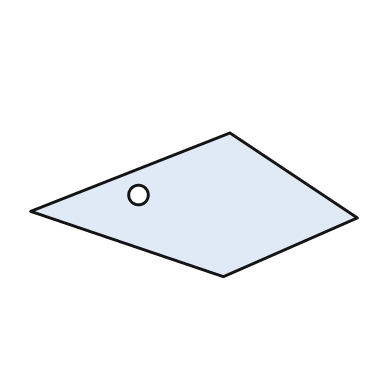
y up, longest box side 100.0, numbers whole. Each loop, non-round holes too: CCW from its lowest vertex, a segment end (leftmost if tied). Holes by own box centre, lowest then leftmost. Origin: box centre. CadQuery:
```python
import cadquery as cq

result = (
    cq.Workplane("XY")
    .moveTo(9.0, -22.0)
    .lineTo(50.0, -4.0)
    .lineTo(11.0, 22.0)
    .lineTo(-50.0, -2.0)
    .close()
    .moveTo(-17.0, 3.0)
    .circle(3.0)
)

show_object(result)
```